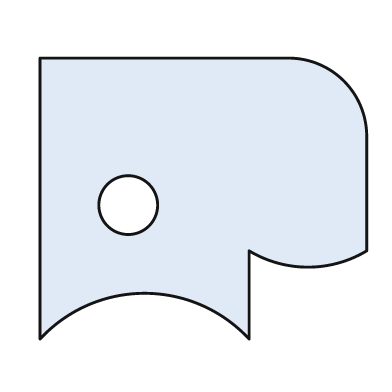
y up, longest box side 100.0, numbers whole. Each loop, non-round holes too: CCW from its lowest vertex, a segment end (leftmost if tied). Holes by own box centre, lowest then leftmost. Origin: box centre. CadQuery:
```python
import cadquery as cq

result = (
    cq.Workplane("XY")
    .moveTo(-50.0, -43.0)
    .threePointArc((-18.0, -29.0), (14.0, -43.0))
    .lineTo(14.0, -16.0)
    .threePointArc((32.0, -21.0), (50.0, -16.0))
    .lineTo(50.0, 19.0)
    .threePointArc((43.0, 36.0), (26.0, 43.0))
    .lineTo(-50.0, 43.0)
    .close()
    .moveTo(-23.0, -2.0)
    .circle(9.0)
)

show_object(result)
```